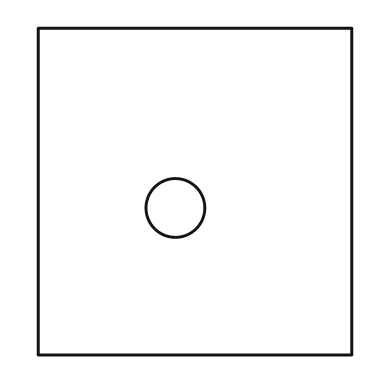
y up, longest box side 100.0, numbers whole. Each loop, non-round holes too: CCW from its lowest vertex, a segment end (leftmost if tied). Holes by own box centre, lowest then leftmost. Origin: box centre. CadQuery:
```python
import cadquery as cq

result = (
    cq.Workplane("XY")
    .moveTo(-48.0, -50.0)
    .lineTo(48.0, -50.0)
    .lineTo(48.0, 50.0)
    .lineTo(-48.0, 50.0)
    .close()
    .moveTo(-6.0, -5.0)
    .circle(9.0)
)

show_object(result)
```